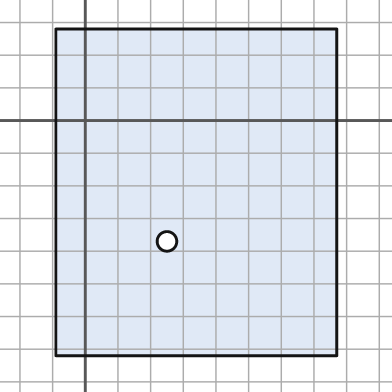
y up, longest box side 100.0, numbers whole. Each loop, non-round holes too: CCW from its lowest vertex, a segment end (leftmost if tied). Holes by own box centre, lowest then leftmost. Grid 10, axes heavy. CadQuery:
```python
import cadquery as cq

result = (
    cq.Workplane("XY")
    .moveTo(-9.0, -72.0)
    .lineTo(77.0, -72.0)
    .lineTo(77.0, 28.0)
    .lineTo(-9.0, 28.0)
    .close()
    .moveTo(25.0, -37.0)
    .circle(3.0)
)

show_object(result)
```